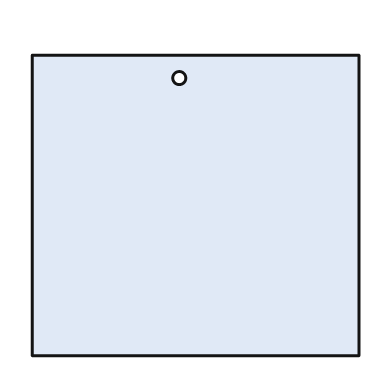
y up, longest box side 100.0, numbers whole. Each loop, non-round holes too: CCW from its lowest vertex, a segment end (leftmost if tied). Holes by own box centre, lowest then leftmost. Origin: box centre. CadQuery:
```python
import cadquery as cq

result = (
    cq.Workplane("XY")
    .moveTo(-50.0, -46.0)
    .lineTo(50.0, -46.0)
    .lineTo(50.0, 46.0)
    .lineTo(-50.0, 46.0)
    .close()
    .moveTo(-5.0, 39.0)
    .circle(2.0)
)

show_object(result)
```